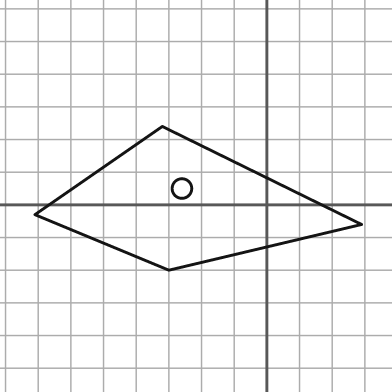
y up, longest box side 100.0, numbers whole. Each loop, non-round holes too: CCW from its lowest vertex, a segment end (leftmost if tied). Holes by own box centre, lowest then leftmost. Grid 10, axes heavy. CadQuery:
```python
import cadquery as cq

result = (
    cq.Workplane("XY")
    .moveTo(-30.0, -20.0)
    .lineTo(29.0, -6.0)
    .lineTo(-32.0, 24.0)
    .lineTo(-71.0, -3.0)
    .close()
    .moveTo(-26.0, 5.0)
    .circle(3.0)
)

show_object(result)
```